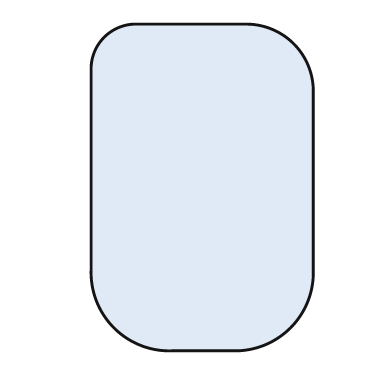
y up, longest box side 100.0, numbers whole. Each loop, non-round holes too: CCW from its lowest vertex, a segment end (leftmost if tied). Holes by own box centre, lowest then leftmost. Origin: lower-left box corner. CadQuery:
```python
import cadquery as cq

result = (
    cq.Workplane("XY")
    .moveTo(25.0, 0.0)
    .lineTo(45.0, 0.0)
    .threePointArc((61.0, 7.0), (68.0, 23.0))
    .lineTo(68.0, 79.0)
    .threePointArc((62.0, 94.0), (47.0, 100.0))
    .lineTo(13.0, 100.0)
    .threePointArc((4.0, 96.0), (0.0, 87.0))
    .lineTo(0.0, 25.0)
    .threePointArc((7.0, 7.0), (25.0, 0.0))
    .close()
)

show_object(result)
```